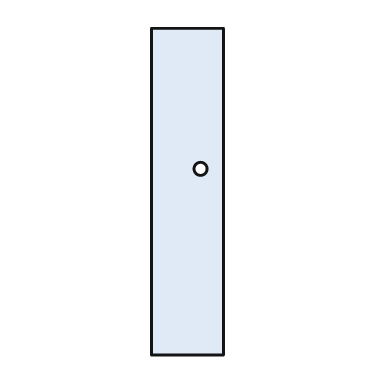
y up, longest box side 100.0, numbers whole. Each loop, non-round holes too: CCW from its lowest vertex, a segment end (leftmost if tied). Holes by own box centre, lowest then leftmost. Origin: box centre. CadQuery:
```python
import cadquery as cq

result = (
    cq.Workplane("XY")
    .moveTo(-11.0, -50.0)
    .lineTo(11.0, -50.0)
    .lineTo(11.0, 50.0)
    .lineTo(-11.0, 50.0)
    .close()
    .moveTo(4.0, 7.0)
    .circle(2.0)
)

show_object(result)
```